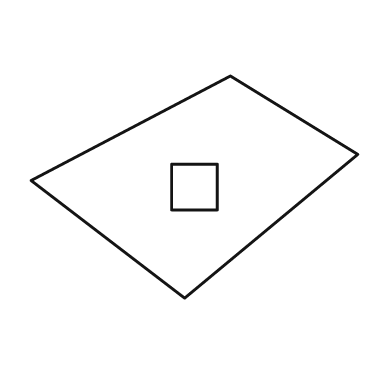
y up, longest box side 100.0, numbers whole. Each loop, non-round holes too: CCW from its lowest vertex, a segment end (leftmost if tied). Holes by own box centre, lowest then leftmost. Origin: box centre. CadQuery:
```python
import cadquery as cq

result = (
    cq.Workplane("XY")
    .moveTo(-3.0, -34.0)
    .lineTo(50.0, 10.0)
    .lineTo(11.0, 34.0)
    .lineTo(-50.0, 2.0)
    .close()
    .moveTo(-7.0, -7.0)
    .lineTo(7.0, -7.0)
    .lineTo(7.0, 7.0)
    .lineTo(-7.0, 7.0)
    .close()
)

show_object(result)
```